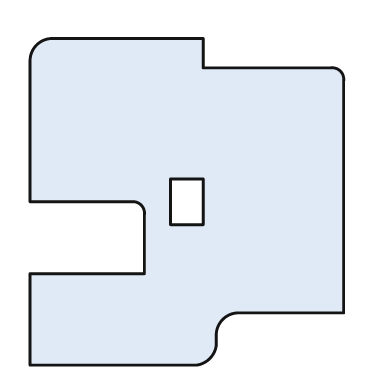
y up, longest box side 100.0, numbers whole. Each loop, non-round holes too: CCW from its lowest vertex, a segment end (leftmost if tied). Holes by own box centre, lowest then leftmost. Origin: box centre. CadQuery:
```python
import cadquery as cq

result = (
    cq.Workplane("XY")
    .moveTo(-48.0, -50.0)
    .lineTo(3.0, -50.0)
    .threePointArc((7.0, -48.0), (9.0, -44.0))
    .lineTo(9.0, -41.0)
    .threePointArc((11.0, -36.0), (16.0, -34.0))
    .lineTo(48.0, -34.0)
    .lineTo(48.0, 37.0)
    .threePointArc((47.0, 40.0), (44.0, 41.0))
    .lineTo(5.0, 41.0)
    .lineTo(5.0, 50.0)
    .lineTo(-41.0, 50.0)
    .threePointArc((-46.0, 48.0), (-48.0, 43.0))
    .lineTo(-48.0, 0.0)
    .lineTo(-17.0, 0.0)
    .threePointArc((-14.0, -1.0), (-13.0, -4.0))
    .lineTo(-13.0, -22.0)
    .lineTo(-48.0, -22.0)
    .close()
    .moveTo(-5.0, -7.0)
    .lineTo(5.0, -7.0)
    .lineTo(5.0, 7.0)
    .lineTo(-5.0, 7.0)
    .close()
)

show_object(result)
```